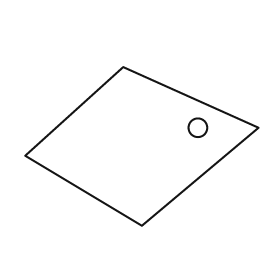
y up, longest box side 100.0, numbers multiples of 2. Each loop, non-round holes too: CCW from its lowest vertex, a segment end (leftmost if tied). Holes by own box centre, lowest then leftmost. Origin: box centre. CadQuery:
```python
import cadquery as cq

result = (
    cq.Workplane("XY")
    .moveTo(0.0, -34.0)
    .lineTo(50.0, 8.0)
    .lineTo(-8.0, 34.0)
    .lineTo(-50.0, -4.0)
    .close()
    .moveTo(24.0, 8.0)
    .circle(4.0)
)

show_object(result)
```